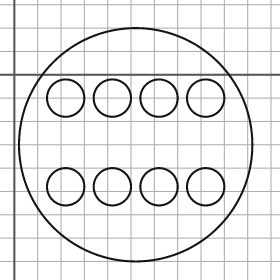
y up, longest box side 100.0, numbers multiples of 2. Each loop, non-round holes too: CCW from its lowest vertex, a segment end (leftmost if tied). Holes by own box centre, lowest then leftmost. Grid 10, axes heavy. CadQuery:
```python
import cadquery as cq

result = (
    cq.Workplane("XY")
    .moveTo(52.0, -30.0)
    .circle(50.0)
    .moveTo(22.0, -48.0)
    .circle(8.0)
    .moveTo(42.0, -48.0)
    .circle(8.0)
    .moveTo(62.0, -48.0)
    .circle(8.0)
    .moveTo(82.0, -48.0)
    .circle(8.0)
    .moveTo(22.0, -10.0)
    .circle(8.0)
    .moveTo(42.0, -10.0)
    .circle(8.0)
    .moveTo(62.0, -10.0)
    .circle(8.0)
    .moveTo(82.0, -10.0)
    .circle(8.0)
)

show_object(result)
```